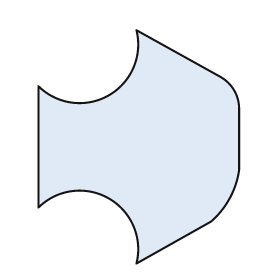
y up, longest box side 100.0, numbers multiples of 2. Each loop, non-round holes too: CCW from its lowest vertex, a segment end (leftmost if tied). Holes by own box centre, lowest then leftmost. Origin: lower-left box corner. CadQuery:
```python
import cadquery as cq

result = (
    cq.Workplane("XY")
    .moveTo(42.0, 0.0)
    .lineTo(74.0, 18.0)
    .threePointArc((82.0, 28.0), (86.0, 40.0))
    .lineTo(86.0, 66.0)
    .threePointArc((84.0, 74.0), (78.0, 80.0))
    .lineTo(42.0, 100.0)
    .threePointArc((30.0, 72.0), (0.0, 76.0))
    .lineTo(0.0, 24.0)
    .threePointArc((30.0, 28.0), (42.0, 0.0))
    .close()
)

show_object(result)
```